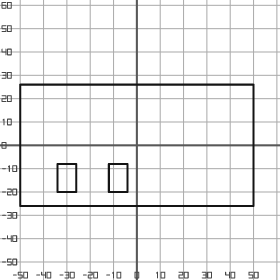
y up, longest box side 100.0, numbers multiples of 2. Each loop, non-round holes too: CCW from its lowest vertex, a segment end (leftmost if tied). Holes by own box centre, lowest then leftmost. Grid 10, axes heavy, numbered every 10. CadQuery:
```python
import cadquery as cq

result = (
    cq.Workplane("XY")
    .moveTo(-50.0, -26.0)
    .lineTo(50.0, -26.0)
    .lineTo(50.0, 26.0)
    .lineTo(-50.0, 26.0)
    .close()
    .moveTo(-34.0, -20.0)
    .lineTo(-26.0, -20.0)
    .lineTo(-26.0, -8.0)
    .lineTo(-34.0, -8.0)
    .close()
    .moveTo(-12.0, -20.0)
    .lineTo(-4.0, -20.0)
    .lineTo(-4.0, -8.0)
    .lineTo(-12.0, -8.0)
    .close()
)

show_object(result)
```